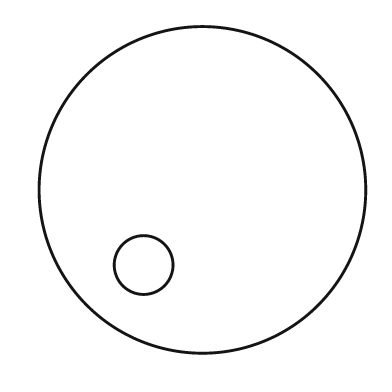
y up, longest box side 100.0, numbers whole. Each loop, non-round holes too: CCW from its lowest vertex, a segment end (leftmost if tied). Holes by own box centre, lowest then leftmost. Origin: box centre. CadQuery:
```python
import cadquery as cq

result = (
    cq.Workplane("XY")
    .moveTo(0.0, 0.0)
    .circle(50.0)
    .moveTo(-18.0, -23.0)
    .circle(9.0)
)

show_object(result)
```